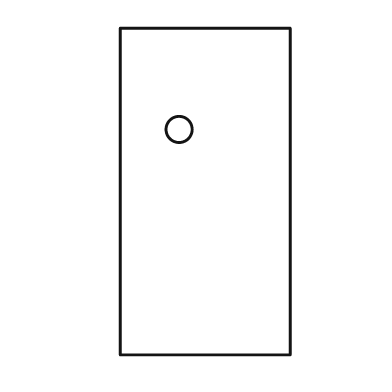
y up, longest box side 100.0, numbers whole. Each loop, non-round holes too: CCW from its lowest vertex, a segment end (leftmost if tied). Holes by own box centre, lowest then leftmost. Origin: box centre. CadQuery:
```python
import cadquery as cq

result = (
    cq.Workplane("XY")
    .moveTo(-26.0, -50.0)
    .lineTo(26.0, -50.0)
    .lineTo(26.0, 50.0)
    .lineTo(-26.0, 50.0)
    .close()
    .moveTo(-8.0, 19.0)
    .circle(4.0)
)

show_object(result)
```